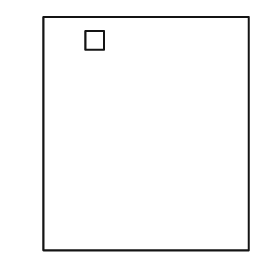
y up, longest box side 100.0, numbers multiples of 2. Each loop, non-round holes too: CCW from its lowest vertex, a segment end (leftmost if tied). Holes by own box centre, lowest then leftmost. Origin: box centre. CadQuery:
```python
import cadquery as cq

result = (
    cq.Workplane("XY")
    .moveTo(-44.0, -50.0)
    .lineTo(44.0, -50.0)
    .lineTo(44.0, 50.0)
    .lineTo(-44.0, 50.0)
    .close()
    .moveTo(-26.0, 36.0)
    .lineTo(-18.0, 36.0)
    .lineTo(-18.0, 44.0)
    .lineTo(-26.0, 44.0)
    .close()
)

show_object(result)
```